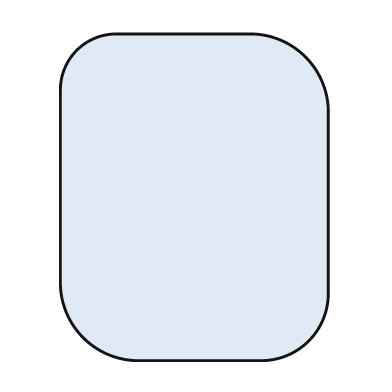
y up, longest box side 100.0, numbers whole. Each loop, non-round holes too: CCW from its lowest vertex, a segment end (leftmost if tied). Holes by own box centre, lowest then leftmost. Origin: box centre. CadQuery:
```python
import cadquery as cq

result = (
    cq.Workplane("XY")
    .moveTo(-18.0, -50.0)
    .lineTo(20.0, -50.0)
    .threePointArc((35.0, -44.0), (41.0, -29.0))
    .lineTo(41.0, 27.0)
    .threePointArc((34.0, 43.0), (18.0, 50.0))
    .lineTo(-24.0, 50.0)
    .threePointArc((-36.0, 45.0), (-41.0, 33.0))
    .lineTo(-41.0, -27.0)
    .threePointArc((-34.0, -43.0), (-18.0, -50.0))
    .close()
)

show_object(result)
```